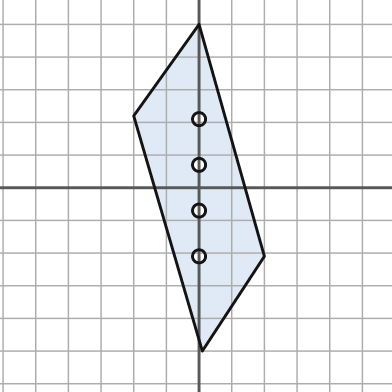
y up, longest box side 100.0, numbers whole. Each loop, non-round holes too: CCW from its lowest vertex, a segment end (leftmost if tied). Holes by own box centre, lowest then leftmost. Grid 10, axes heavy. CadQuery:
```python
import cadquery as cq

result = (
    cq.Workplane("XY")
    .moveTo(1.0, -50.0)
    .lineTo(20.0, -21.0)
    .lineTo(0.0, 50.0)
    .lineTo(-20.0, 22.0)
    .close()
    .moveTo(0.0, -21.0)
    .circle(2.0)
    .moveTo(0.0, -7.0)
    .circle(2.0)
    .moveTo(0.0, 7.0)
    .circle(2.0)
    .moveTo(0.0, 21.0)
    .circle(2.0)
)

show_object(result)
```